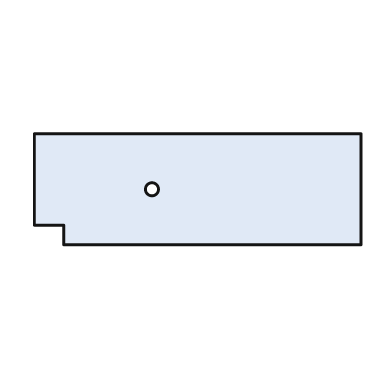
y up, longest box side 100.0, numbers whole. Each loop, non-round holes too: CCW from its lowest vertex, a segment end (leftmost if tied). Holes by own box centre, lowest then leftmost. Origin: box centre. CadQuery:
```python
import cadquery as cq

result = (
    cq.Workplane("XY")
    .moveTo(-41.0, -17.0)
    .lineTo(50.0, -17.0)
    .lineTo(50.0, 17.0)
    .lineTo(-50.0, 17.0)
    .lineTo(-50.0, -11.0)
    .lineTo(-41.0, -11.0)
    .close()
    .moveTo(-14.0, 0.0)
    .circle(2.0)
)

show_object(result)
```